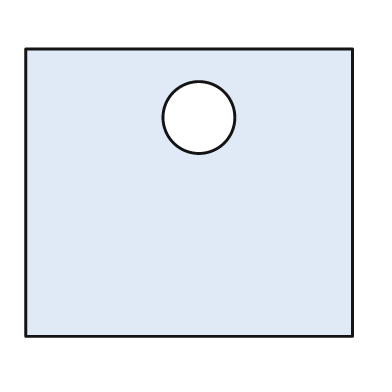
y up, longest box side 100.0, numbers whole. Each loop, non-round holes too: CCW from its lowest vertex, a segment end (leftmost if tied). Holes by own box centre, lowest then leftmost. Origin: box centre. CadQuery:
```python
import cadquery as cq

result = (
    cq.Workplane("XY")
    .moveTo(-50.0, -44.0)
    .lineTo(50.0, -44.0)
    .lineTo(50.0, 44.0)
    .lineTo(-50.0, 44.0)
    .close()
    .moveTo(3.0, 23.0)
    .circle(11.0)
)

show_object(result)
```